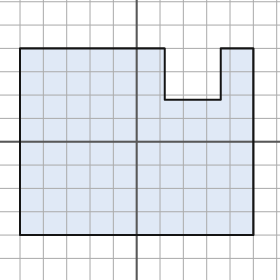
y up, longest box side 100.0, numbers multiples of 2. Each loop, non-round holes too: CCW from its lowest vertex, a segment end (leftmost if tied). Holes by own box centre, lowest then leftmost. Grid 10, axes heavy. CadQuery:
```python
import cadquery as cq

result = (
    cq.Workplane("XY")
    .moveTo(-50.0, -40.0)
    .lineTo(50.0, -40.0)
    .lineTo(50.0, 40.0)
    .lineTo(36.0, 40.0)
    .lineTo(36.0, 18.0)
    .lineTo(12.0, 18.0)
    .lineTo(12.0, 40.0)
    .lineTo(-50.0, 40.0)
    .close()
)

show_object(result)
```